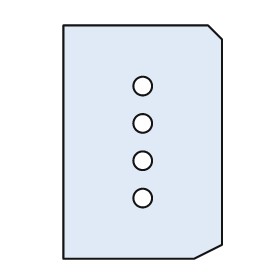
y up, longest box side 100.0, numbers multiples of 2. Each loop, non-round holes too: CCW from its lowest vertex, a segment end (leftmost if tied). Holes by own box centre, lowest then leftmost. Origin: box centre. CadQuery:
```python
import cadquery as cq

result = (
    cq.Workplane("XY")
    .moveTo(-34.0, -50.0)
    .lineTo(22.0, -50.0)
    .lineTo(34.0, -44.0)
    .lineTo(34.0, 44.0)
    .lineTo(28.0, 50.0)
    .lineTo(-34.0, 50.0)
    .close()
    .moveTo(0.0, -24.0)
    .circle(4.0)
    .moveTo(0.0, -8.0)
    .circle(4.0)
    .moveTo(0.0, 8.0)
    .circle(4.0)
    .moveTo(0.0, 24.0)
    .circle(4.0)
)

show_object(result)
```